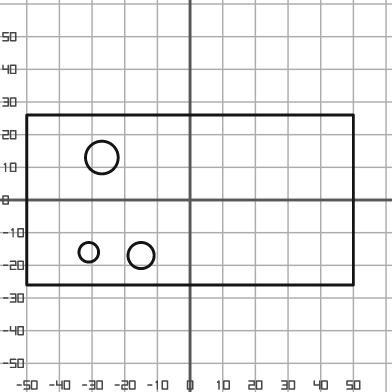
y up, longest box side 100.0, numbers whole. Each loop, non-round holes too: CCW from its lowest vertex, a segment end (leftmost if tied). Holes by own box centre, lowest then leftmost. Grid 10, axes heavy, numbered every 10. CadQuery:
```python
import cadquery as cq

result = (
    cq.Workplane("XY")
    .moveTo(-50.0, -26.0)
    .lineTo(50.0, -26.0)
    .lineTo(50.0, 26.0)
    .lineTo(-50.0, 26.0)
    .close()
    .moveTo(-15.0, -17.0)
    .circle(4.0)
    .moveTo(-31.0, -16.0)
    .circle(3.0)
    .moveTo(-27.0, 13.0)
    .circle(5.0)
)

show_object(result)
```